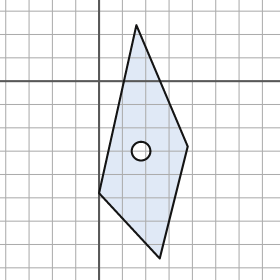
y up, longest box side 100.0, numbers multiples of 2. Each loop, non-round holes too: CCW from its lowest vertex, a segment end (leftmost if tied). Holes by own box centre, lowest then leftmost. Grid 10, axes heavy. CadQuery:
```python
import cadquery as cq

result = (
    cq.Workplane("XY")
    .moveTo(26.0, -76.0)
    .lineTo(38.0, -28.0)
    .lineTo(16.0, 24.0)
    .lineTo(0.0, -48.0)
    .close()
    .moveTo(18.0, -30.0)
    .circle(4.0)
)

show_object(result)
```